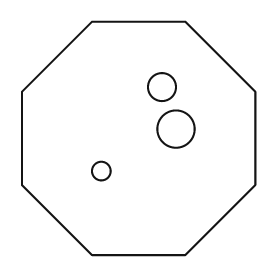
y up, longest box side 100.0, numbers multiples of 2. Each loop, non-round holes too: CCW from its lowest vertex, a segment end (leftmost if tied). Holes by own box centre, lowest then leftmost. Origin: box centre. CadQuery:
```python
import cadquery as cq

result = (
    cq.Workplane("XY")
    .moveTo(-20.0, -50.0)
    .lineTo(20.0, -50.0)
    .lineTo(50.0, -20.0)
    .lineTo(50.0, 20.0)
    .lineTo(20.0, 50.0)
    .lineTo(-20.0, 50.0)
    .lineTo(-50.0, 20.0)
    .lineTo(-50.0, -20.0)
    .close()
    .moveTo(-16.0, -14.0)
    .circle(4.0)
    .moveTo(16.0, 4.0)
    .circle(8.0)
    .moveTo(10.0, 22.0)
    .circle(6.0)
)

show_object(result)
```